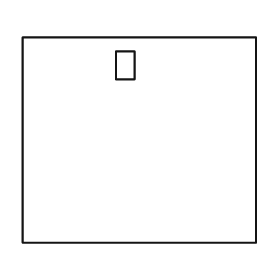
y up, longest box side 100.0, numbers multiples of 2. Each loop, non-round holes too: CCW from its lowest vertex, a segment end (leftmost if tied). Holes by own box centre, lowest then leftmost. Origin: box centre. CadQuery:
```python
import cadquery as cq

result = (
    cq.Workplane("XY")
    .moveTo(-50.0, -44.0)
    .lineTo(50.0, -44.0)
    .lineTo(50.0, 44.0)
    .lineTo(-50.0, 44.0)
    .close()
    .moveTo(-10.0, 26.0)
    .lineTo(-2.0, 26.0)
    .lineTo(-2.0, 38.0)
    .lineTo(-10.0, 38.0)
    .close()
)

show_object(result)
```